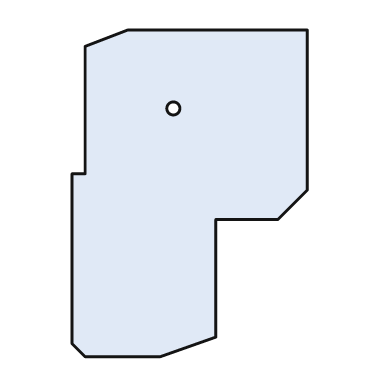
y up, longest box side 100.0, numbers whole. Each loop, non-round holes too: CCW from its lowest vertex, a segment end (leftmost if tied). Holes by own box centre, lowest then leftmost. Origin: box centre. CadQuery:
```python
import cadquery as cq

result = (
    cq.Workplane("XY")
    .moveTo(-32.0, -50.0)
    .lineTo(-9.0, -50.0)
    .lineTo(8.0, -44.0)
    .lineTo(8.0, -8.0)
    .lineTo(27.0, -8.0)
    .lineTo(36.0, 1.0)
    .lineTo(36.0, 50.0)
    .lineTo(-19.0, 50.0)
    .lineTo(-32.0, 45.0)
    .lineTo(-32.0, 6.0)
    .lineTo(-36.0, 6.0)
    .lineTo(-36.0, -46.0)
    .close()
    .moveTo(-5.0, 26.0)
    .circle(2.0)
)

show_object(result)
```